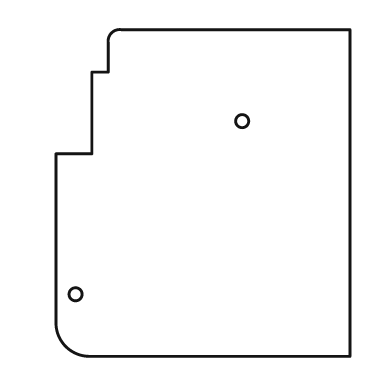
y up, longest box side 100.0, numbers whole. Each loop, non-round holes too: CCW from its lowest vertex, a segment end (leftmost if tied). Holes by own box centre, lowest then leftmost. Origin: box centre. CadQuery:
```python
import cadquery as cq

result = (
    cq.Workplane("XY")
    .moveTo(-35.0, -50.0)
    .lineTo(45.0, -50.0)
    .lineTo(45.0, 50.0)
    .lineTo(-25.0, 50.0)
    .threePointArc((-28.0, 49.0), (-29.0, 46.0))
    .lineTo(-29.0, 37.0)
    .lineTo(-34.0, 37.0)
    .lineTo(-34.0, 12.0)
    .lineTo(-45.0, 12.0)
    .lineTo(-45.0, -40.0)
    .threePointArc((-42.0, -47.0), (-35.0, -50.0))
    .close()
    .moveTo(-39.0, -31.0)
    .circle(2.0)
    .moveTo(12.0, 22.0)
    .circle(2.0)
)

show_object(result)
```